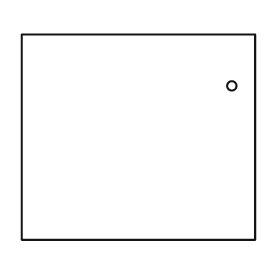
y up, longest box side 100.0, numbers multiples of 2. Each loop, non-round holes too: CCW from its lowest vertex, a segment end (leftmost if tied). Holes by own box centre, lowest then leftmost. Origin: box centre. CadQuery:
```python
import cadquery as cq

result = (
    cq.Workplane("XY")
    .moveTo(-50.0, -44.0)
    .lineTo(50.0, -44.0)
    .lineTo(50.0, 44.0)
    .lineTo(-50.0, 44.0)
    .close()
    .moveTo(40.0, 22.0)
    .circle(2.0)
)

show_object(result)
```